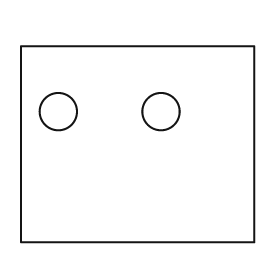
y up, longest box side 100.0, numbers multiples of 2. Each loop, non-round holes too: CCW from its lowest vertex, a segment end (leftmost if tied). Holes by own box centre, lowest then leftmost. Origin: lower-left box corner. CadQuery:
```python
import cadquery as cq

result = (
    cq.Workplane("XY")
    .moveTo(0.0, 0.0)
    .lineTo(100.0, 0.0)
    .lineTo(100.0, 84.0)
    .lineTo(0.0, 84.0)
    .close()
    .moveTo(16.0, 56.0)
    .circle(8.0)
    .moveTo(60.0, 56.0)
    .circle(8.0)
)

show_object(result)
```